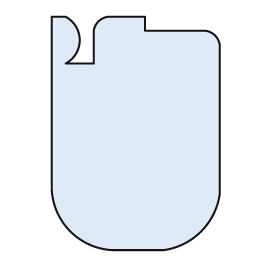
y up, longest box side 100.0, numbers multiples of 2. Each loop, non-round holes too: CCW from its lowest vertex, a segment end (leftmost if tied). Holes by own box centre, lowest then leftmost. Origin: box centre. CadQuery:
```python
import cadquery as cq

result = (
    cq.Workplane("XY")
    .moveTo(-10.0, -50.0)
    .lineTo(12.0, -50.0)
    .threePointArc((28.0, -42.0), (36.0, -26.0))
    .lineTo(36.0, 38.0)
    .threePointArc((34.0, 42.0), (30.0, 44.0))
    .lineTo(4.0, 44.0)
    .lineTo(4.0, 50.0)
    .lineTo(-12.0, 50.0)
    .threePointArc((-16.0, 48.0), (-18.0, 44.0))
    .lineTo(-18.0, 30.0)
    .lineTo(-30.0, 30.0)
    .threePointArc((-24.0, 40.0), (-30.0, 50.0))
    .lineTo(-36.0, 50.0)
    .lineTo(-36.0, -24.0)
    .threePointArc((-28.0, -42.0), (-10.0, -50.0))
    .close()
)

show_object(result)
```